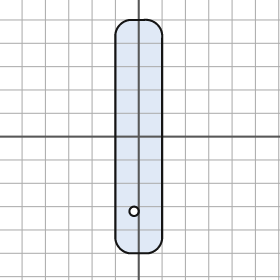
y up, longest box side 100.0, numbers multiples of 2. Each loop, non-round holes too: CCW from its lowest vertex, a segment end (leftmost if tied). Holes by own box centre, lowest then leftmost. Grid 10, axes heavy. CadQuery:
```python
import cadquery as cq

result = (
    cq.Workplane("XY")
    .moveTo(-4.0, -50.0)
    .lineTo(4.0, -50.0)
    .threePointArc((8.0, -48.0), (10.0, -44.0))
    .lineTo(10.0, 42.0)
    .threePointArc((8.0, 48.0), (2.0, 50.0))
    .lineTo(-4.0, 50.0)
    .threePointArc((-8.0, 48.0), (-10.0, 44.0))
    .lineTo(-10.0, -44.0)
    .threePointArc((-8.0, -48.0), (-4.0, -50.0))
    .close()
    .moveTo(-2.0, -32.0)
    .circle(2.0)
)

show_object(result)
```